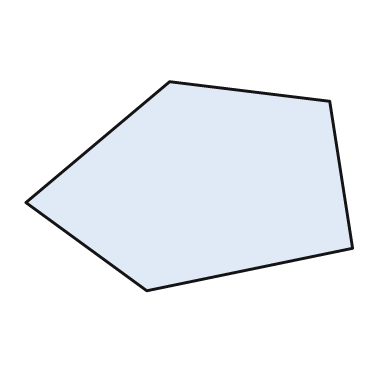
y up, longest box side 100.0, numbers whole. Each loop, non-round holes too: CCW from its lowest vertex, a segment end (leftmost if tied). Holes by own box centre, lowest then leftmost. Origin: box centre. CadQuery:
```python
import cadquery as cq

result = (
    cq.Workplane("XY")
    .moveTo(-13.0, -32.0)
    .lineTo(50.0, -19.0)
    .lineTo(43.0, 26.0)
    .lineTo(-6.0, 32.0)
    .lineTo(-50.0, -5.0)
    .close()
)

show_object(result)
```